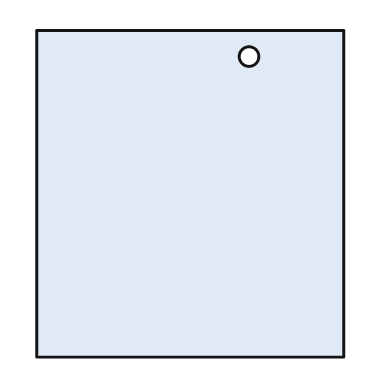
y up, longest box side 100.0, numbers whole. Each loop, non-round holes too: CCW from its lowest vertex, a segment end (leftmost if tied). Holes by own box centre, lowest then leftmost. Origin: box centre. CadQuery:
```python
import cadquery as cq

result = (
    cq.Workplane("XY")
    .moveTo(-47.0, -50.0)
    .lineTo(47.0, -50.0)
    .lineTo(47.0, 50.0)
    .lineTo(-47.0, 50.0)
    .close()
    .moveTo(18.0, 42.0)
    .circle(3.0)
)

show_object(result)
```